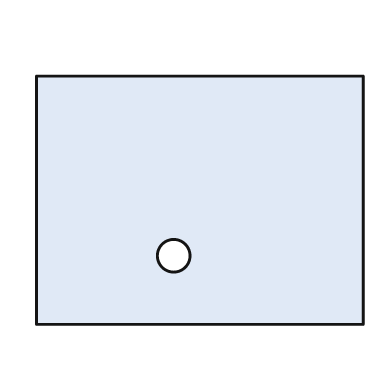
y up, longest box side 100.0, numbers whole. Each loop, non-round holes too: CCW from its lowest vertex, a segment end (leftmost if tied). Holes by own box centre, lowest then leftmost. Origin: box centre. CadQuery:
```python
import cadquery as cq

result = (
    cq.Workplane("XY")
    .moveTo(-50.0, -38.0)
    .lineTo(50.0, -38.0)
    .lineTo(50.0, 38.0)
    .lineTo(-50.0, 38.0)
    .close()
    .moveTo(-8.0, -17.0)
    .circle(5.0)
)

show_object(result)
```